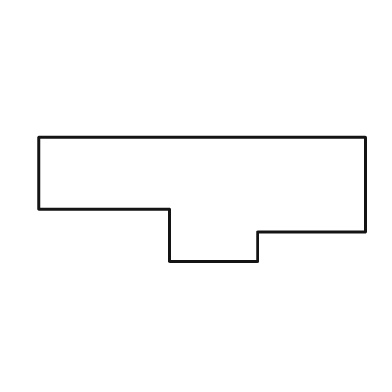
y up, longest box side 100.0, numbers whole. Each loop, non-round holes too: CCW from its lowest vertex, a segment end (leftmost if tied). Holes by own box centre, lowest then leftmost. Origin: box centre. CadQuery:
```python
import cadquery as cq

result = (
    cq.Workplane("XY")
    .moveTo(-10.0, -19.0)
    .lineTo(17.0, -19.0)
    .lineTo(17.0, -10.0)
    .lineTo(50.0, -10.0)
    .lineTo(50.0, 19.0)
    .lineTo(-50.0, 19.0)
    .lineTo(-50.0, -3.0)
    .lineTo(-10.0, -3.0)
    .close()
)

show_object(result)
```